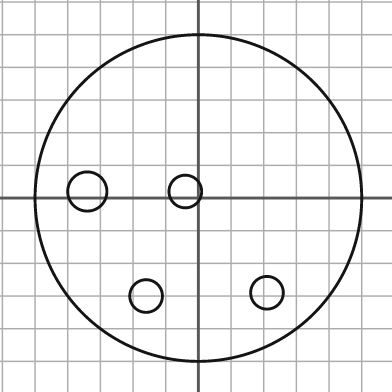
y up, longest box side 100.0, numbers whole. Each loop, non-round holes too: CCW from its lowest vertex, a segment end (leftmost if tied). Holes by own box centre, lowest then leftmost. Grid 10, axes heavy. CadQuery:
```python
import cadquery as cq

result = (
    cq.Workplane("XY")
    .moveTo(0.0, 0.0)
    .circle(50.0)
    .moveTo(-16.0, -30.0)
    .circle(5.0)
    .moveTo(21.0, -29.0)
    .circle(5.0)
    .moveTo(-34.0, 2.0)
    .circle(6.0)
    .moveTo(-4.0, 2.0)
    .circle(5.0)
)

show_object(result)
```